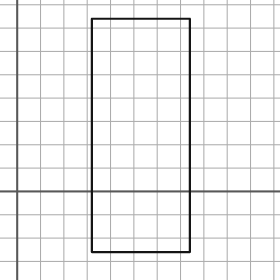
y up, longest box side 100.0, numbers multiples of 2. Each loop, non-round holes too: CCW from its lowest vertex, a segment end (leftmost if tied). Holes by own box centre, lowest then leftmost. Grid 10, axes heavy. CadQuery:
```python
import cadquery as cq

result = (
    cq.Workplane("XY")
    .moveTo(32.0, -26.0)
    .lineTo(74.0, -26.0)
    .lineTo(74.0, 74.0)
    .lineTo(32.0, 74.0)
    .close()
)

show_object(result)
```